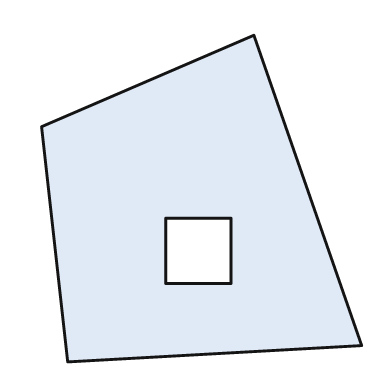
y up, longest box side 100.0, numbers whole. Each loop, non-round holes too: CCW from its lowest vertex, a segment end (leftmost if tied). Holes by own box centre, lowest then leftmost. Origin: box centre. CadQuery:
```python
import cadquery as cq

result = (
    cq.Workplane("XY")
    .moveTo(-41.0, -50.0)
    .lineTo(49.0, -45.0)
    .lineTo(16.0, 50.0)
    .lineTo(-49.0, 22.0)
    .close()
    .moveTo(-11.0, -26.0)
    .lineTo(9.0, -26.0)
    .lineTo(9.0, -6.0)
    .lineTo(-11.0, -6.0)
    .close()
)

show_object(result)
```